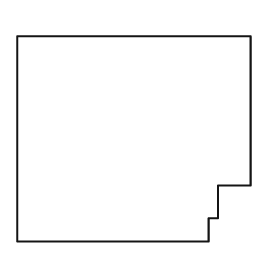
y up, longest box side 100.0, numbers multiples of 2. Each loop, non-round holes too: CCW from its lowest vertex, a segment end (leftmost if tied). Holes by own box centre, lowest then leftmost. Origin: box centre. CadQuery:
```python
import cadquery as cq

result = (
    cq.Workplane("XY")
    .moveTo(-50.0, -44.0)
    .lineTo(32.0, -44.0)
    .lineTo(32.0, -34.0)
    .lineTo(36.0, -34.0)
    .lineTo(36.0, -20.0)
    .lineTo(50.0, -20.0)
    .lineTo(50.0, 44.0)
    .lineTo(-50.0, 44.0)
    .close()
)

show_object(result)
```